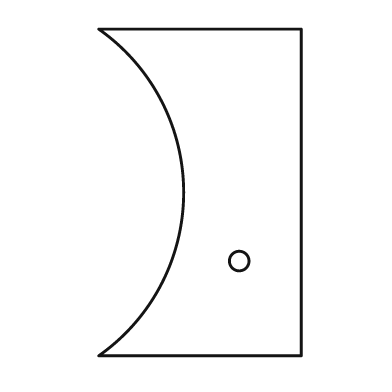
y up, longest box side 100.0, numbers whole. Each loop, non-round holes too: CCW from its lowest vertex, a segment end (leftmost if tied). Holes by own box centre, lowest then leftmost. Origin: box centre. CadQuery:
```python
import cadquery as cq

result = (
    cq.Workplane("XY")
    .moveTo(-31.0, -50.0)
    .lineTo(31.0, -50.0)
    .lineTo(31.0, 50.0)
    .lineTo(-31.0, 50.0)
    .threePointArc((-5.0, 0.0), (-31.0, -50.0))
    .close()
    .moveTo(12.0, -21.0)
    .circle(3.0)
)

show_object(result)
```